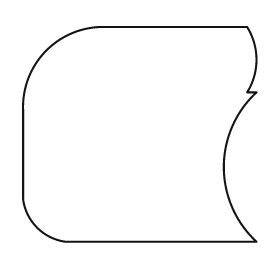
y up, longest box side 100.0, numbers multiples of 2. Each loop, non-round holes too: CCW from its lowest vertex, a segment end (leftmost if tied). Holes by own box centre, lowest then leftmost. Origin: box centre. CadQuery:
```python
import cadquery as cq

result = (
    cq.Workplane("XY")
    .moveTo(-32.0, -46.0)
    .lineTo(50.0, -46.0)
    .threePointArc((36.0, -14.0), (50.0, 18.0))
    .lineTo(46.0, 18.0)
    .threePointArc((50.0, 32.0), (46.0, 46.0))
    .lineTo(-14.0, 46.0)
    .threePointArc((-40.0, 36.0), (-50.0, 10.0))
    .lineTo(-50.0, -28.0)
    .threePointArc((-44.0, -40.0), (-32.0, -46.0))
    .close()
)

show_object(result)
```